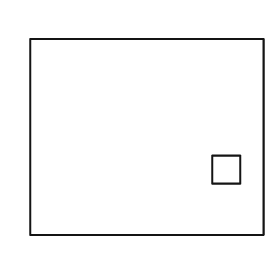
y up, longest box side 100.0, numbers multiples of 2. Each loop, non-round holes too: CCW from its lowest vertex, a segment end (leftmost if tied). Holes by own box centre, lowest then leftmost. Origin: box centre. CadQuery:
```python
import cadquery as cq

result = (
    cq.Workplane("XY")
    .moveTo(-50.0, -42.0)
    .lineTo(50.0, -42.0)
    .lineTo(50.0, 42.0)
    .lineTo(-50.0, 42.0)
    .close()
    .moveTo(28.0, -20.0)
    .lineTo(40.0, -20.0)
    .lineTo(40.0, -8.0)
    .lineTo(28.0, -8.0)
    .close()
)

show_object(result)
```